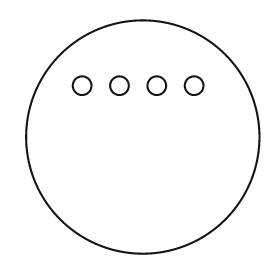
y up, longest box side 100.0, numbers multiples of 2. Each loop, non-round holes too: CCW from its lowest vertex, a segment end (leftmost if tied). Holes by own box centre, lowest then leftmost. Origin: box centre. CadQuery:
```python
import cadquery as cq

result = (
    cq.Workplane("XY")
    .moveTo(0.0, 0.0)
    .circle(50.0)
    .moveTo(-26.0, 22.0)
    .circle(4.0)
    .moveTo(-10.0, 22.0)
    .circle(4.0)
    .moveTo(6.0, 22.0)
    .circle(4.0)
    .moveTo(22.0, 22.0)
    .circle(4.0)
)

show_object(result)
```